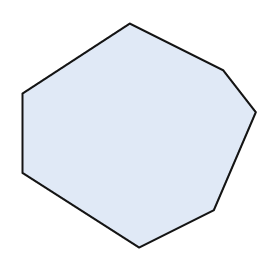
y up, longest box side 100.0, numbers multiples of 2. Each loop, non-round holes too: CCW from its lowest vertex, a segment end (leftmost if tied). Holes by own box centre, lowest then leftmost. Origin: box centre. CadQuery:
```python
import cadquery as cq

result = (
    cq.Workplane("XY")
    .moveTo(0.0, -48.0)
    .lineTo(32.0, -32.0)
    .lineTo(50.0, 10.0)
    .lineTo(36.0, 28.0)
    .lineTo(-4.0, 48.0)
    .lineTo(-50.0, 18.0)
    .lineTo(-50.0, -16.0)
    .close()
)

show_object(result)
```